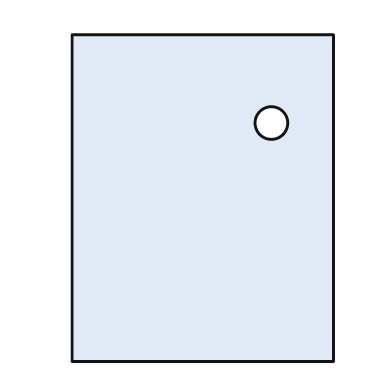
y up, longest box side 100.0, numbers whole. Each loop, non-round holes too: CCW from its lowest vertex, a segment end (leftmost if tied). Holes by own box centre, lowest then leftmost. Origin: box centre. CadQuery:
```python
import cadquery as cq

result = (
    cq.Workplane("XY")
    .moveTo(-40.0, -50.0)
    .lineTo(40.0, -50.0)
    .lineTo(40.0, 50.0)
    .lineTo(-40.0, 50.0)
    .close()
    .moveTo(21.0, 23.0)
    .circle(5.0)
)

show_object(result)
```